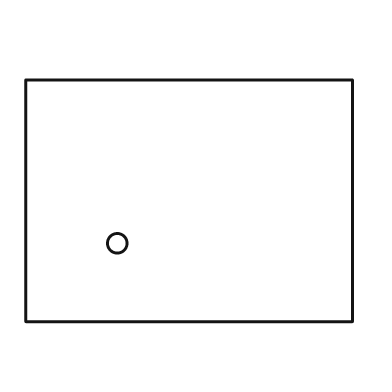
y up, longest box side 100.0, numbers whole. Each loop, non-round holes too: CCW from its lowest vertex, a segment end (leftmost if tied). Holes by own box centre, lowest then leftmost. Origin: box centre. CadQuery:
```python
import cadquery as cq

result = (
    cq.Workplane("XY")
    .moveTo(-50.0, -37.0)
    .lineTo(50.0, -37.0)
    .lineTo(50.0, 37.0)
    .lineTo(-50.0, 37.0)
    .close()
    .moveTo(-22.0, -13.0)
    .circle(3.0)
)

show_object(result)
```